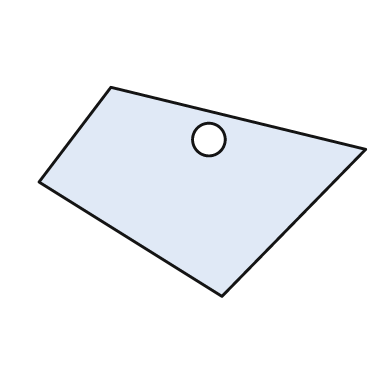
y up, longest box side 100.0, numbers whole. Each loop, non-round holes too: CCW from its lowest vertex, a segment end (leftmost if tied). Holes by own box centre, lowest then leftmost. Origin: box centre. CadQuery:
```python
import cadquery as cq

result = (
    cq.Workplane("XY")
    .moveTo(6.0, -32.0)
    .lineTo(50.0, 13.0)
    .lineTo(-28.0, 32.0)
    .lineTo(-50.0, 3.0)
    .close()
    .moveTo(2.0, 16.0)
    .circle(5.0)
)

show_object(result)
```